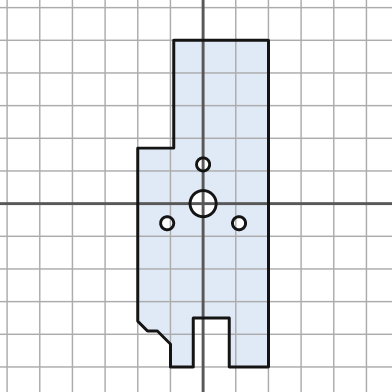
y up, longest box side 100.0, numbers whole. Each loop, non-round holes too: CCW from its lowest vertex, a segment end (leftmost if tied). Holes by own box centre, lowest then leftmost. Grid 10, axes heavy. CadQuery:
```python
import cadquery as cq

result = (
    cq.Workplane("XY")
    .moveTo(-10.0, -50.0)
    .lineTo(-3.0, -50.0)
    .lineTo(-3.0, -35.0)
    .lineTo(8.0, -35.0)
    .lineTo(8.0, -50.0)
    .lineTo(20.0, -50.0)
    .lineTo(20.0, 50.0)
    .lineTo(-9.0, 50.0)
    .lineTo(-9.0, 17.0)
    .lineTo(-20.0, 17.0)
    .lineTo(-20.0, -36.0)
    .lineTo(-17.0, -39.0)
    .lineTo(-14.0, -39.0)
    .lineTo(-10.0, -43.0)
    .close()
    .moveTo(-11.0, -6.0)
    .circle(2.0)
    .moveTo(11.0, -6.0)
    .circle(2.0)
    .moveTo(0.0, 0.0)
    .circle(4.0)
    .moveTo(0.0, 12.0)
    .circle(2.0)
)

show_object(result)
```